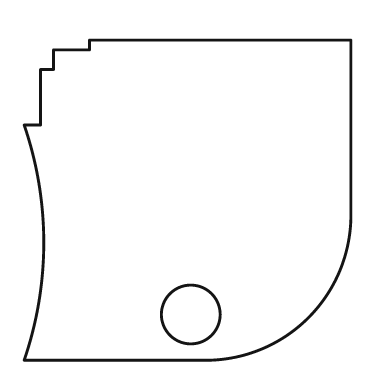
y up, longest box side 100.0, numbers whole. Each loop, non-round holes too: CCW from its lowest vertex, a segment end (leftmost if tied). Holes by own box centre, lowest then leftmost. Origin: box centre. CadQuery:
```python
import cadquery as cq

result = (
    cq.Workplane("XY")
    .moveTo(-50.0, -49.0)
    .lineTo(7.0, -49.0)
    .threePointArc((37.0, -36.0), (50.0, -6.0))
    .lineTo(50.0, 49.0)
    .lineTo(-30.0, 49.0)
    .lineTo(-30.0, 46.0)
    .lineTo(-41.0, 46.0)
    .lineTo(-41.0, 40.0)
    .lineTo(-45.0, 40.0)
    .lineTo(-45.0, 23.0)
    .lineTo(-50.0, 23.0)
    .threePointArc((-44.0, -13.0), (-50.0, -49.0))
    .close()
    .moveTo(1.0, -35.0)
    .circle(9.0)
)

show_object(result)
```